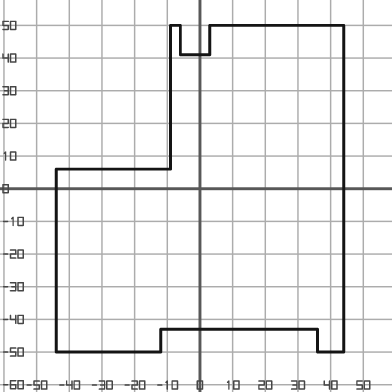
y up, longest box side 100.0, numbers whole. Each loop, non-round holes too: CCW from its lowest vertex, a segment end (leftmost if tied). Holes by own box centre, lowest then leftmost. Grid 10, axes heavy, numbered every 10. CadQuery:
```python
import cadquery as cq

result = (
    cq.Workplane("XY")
    .moveTo(-44.0, -50.0)
    .lineTo(-12.0, -50.0)
    .lineTo(-12.0, -43.0)
    .lineTo(36.0, -43.0)
    .lineTo(36.0, -50.0)
    .lineTo(44.0, -50.0)
    .lineTo(44.0, 50.0)
    .lineTo(3.0, 50.0)
    .lineTo(3.0, 41.0)
    .lineTo(-6.0, 41.0)
    .lineTo(-6.0, 50.0)
    .lineTo(-9.0, 50.0)
    .lineTo(-9.0, 6.0)
    .lineTo(-44.0, 6.0)
    .close()
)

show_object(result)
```